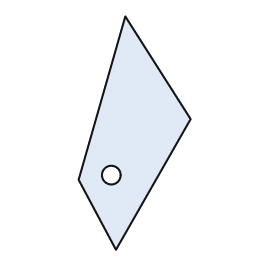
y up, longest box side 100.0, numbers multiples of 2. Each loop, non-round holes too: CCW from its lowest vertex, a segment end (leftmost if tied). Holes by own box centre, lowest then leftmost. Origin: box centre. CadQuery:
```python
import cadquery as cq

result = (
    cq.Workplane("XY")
    .moveTo(-8.0, -50.0)
    .lineTo(24.0, 6.0)
    .lineTo(-4.0, 50.0)
    .lineTo(-24.0, -20.0)
    .close()
    .moveTo(-10.0, -18.0)
    .circle(4.0)
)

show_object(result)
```